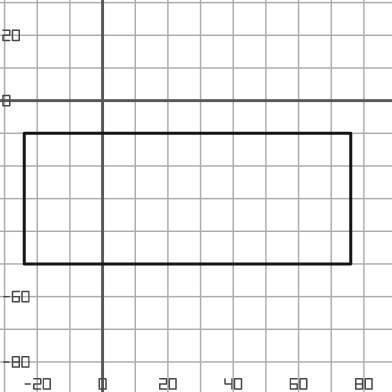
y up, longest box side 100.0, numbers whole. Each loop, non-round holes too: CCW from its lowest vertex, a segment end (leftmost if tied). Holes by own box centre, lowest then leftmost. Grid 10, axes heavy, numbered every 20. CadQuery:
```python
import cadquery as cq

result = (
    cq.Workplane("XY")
    .moveTo(-24.0, -50.0)
    .lineTo(76.0, -50.0)
    .lineTo(76.0, -10.0)
    .lineTo(-24.0, -10.0)
    .close()
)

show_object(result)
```